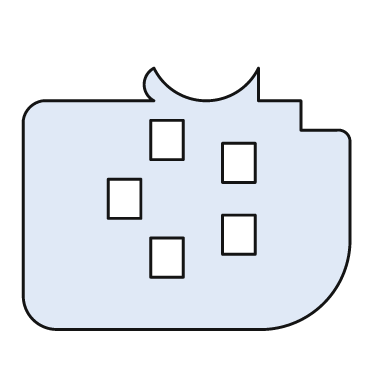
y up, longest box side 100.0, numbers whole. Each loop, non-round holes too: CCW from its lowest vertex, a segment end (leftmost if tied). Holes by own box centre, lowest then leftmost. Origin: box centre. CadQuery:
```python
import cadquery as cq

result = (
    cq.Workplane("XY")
    .moveTo(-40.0, -40.0)
    .lineTo(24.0, -40.0)
    .threePointArc((42.0, -32.0), (50.0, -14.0))
    .lineTo(50.0, 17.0)
    .threePointArc((49.0, 20.0), (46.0, 21.0))
    .lineTo(35.0, 21.0)
    .lineTo(35.0, 30.0)
    .lineTo(22.0, 30.0)
    .lineTo(22.0, 40.0)
    .threePointArc((6.0, 30.0), (-10.0, 40.0))
    .threePointArc((-13.0, 35.0), (-10.0, 30.0))
    .lineTo(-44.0, 30.0)
    .threePointArc((-48.0, 28.0), (-50.0, 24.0))
    .lineTo(-50.0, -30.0)
    .threePointArc((-47.0, -37.0), (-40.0, -40.0))
    .close()
    .moveTo(-11.0, -24.0)
    .lineTo(-1.0, -24.0)
    .lineTo(-1.0, -12.0)
    .lineTo(-11.0, -12.0)
    .close()
    .moveTo(11.0, -17.0)
    .lineTo(21.0, -17.0)
    .lineTo(21.0, -5.0)
    .lineTo(11.0, -5.0)
    .close()
    .moveTo(-24.0, -6.0)
    .lineTo(-14.0, -6.0)
    .lineTo(-14.0, 6.0)
    .lineTo(-24.0, 6.0)
    .close()
    .moveTo(11.0, 5.0)
    .lineTo(21.0, 5.0)
    .lineTo(21.0, 17.0)
    .lineTo(11.0, 17.0)
    .close()
    .moveTo(-11.0, 12.0)
    .lineTo(-1.0, 12.0)
    .lineTo(-1.0, 24.0)
    .lineTo(-11.0, 24.0)
    .close()
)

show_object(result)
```